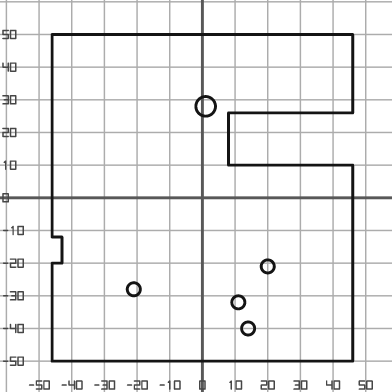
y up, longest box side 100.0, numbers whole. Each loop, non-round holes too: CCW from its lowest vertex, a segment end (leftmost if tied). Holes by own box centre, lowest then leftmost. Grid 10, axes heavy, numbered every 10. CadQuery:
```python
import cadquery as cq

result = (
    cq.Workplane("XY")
    .moveTo(-46.0, -50.0)
    .lineTo(46.0, -50.0)
    .lineTo(46.0, 10.0)
    .lineTo(8.0, 10.0)
    .lineTo(8.0, 26.0)
    .lineTo(46.0, 26.0)
    .lineTo(46.0, 50.0)
    .lineTo(-46.0, 50.0)
    .lineTo(-46.0, -12.0)
    .lineTo(-43.0, -12.0)
    .lineTo(-43.0, -20.0)
    .lineTo(-46.0, -20.0)
    .close()
    .moveTo(14.0, -40.0)
    .circle(2.0)
    .moveTo(11.0, -32.0)
    .circle(2.0)
    .moveTo(-21.0, -28.0)
    .circle(2.0)
    .moveTo(20.0, -21.0)
    .circle(2.0)
    .moveTo(1.0, 28.0)
    .circle(3.0)
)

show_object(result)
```